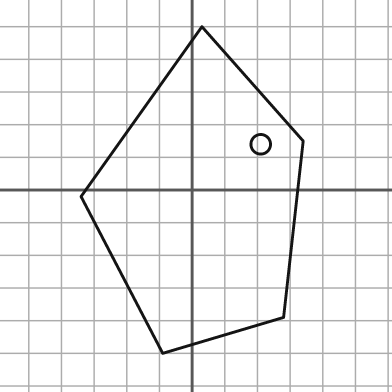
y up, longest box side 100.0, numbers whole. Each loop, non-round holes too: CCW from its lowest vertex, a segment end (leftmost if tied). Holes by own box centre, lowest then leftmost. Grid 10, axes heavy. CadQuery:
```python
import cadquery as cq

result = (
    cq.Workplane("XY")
    .moveTo(-9.0, -50.0)
    .lineTo(28.0, -39.0)
    .lineTo(34.0, 15.0)
    .lineTo(3.0, 50.0)
    .lineTo(-34.0, -2.0)
    .close()
    .moveTo(21.0, 14.0)
    .circle(3.0)
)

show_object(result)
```